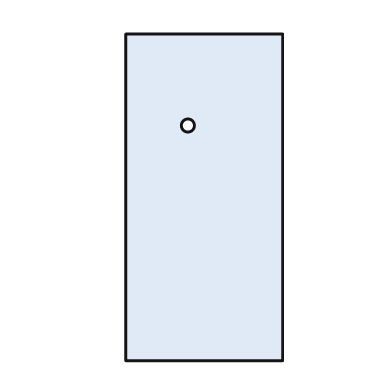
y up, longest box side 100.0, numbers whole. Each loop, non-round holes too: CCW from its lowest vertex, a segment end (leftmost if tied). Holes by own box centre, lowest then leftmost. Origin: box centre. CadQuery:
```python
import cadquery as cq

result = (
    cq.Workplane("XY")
    .moveTo(-24.0, -50.0)
    .lineTo(24.0, -50.0)
    .lineTo(24.0, 50.0)
    .lineTo(-24.0, 50.0)
    .close()
    .moveTo(-5.0, 22.0)
    .circle(2.0)
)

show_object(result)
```